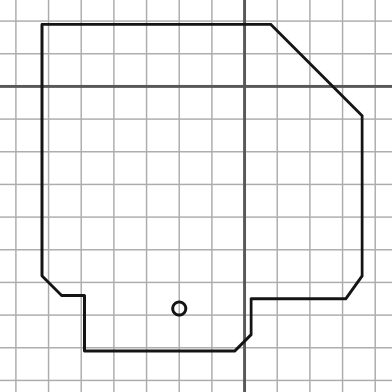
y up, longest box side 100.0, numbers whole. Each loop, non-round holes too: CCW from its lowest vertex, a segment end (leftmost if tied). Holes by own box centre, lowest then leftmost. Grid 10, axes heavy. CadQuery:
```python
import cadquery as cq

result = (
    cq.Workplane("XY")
    .moveTo(-49.0, -81.0)
    .lineTo(-3.0, -81.0)
    .lineTo(2.0, -76.0)
    .lineTo(2.0, -65.0)
    .lineTo(31.0, -65.0)
    .lineTo(36.0, -58.0)
    .lineTo(36.0, -9.0)
    .lineTo(8.0, 19.0)
    .lineTo(-62.0, 19.0)
    .lineTo(-62.0, -58.0)
    .lineTo(-56.0, -64.0)
    .lineTo(-49.0, -64.0)
    .close()
    .moveTo(-20.0, -68.0)
    .circle(2.0)
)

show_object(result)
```